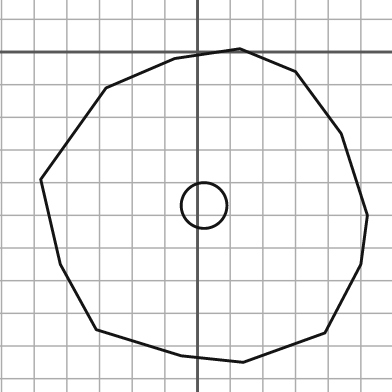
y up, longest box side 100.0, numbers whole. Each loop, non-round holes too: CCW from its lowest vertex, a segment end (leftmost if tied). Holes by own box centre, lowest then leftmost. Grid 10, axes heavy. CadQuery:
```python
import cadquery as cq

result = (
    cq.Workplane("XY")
    .moveTo(14.0, -95.0)
    .lineTo(39.0, -86.0)
    .lineTo(50.0, -65.0)
    .lineTo(52.0, -50.0)
    .lineTo(44.0, -25.0)
    .lineTo(30.0, -6.0)
    .lineTo(13.0, 1.0)
    .lineTo(-7.0, -2.0)
    .lineTo(-28.0, -11.0)
    .lineTo(-48.0, -39.0)
    .lineTo(-42.0, -65.0)
    .lineTo(-31.0, -85.0)
    .lineTo(-5.0, -93.0)
    .close()
    .moveTo(2.0, -47.0)
    .circle(7.0)
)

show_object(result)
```